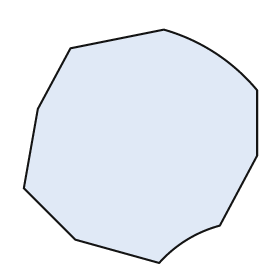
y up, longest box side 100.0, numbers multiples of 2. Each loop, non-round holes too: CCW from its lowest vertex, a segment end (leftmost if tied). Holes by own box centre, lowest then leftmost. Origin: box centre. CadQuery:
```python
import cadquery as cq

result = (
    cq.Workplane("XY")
    .moveTo(8.0, -50.0)
    .threePointArc((20.0, -40.0), (34.0, -34.0))
    .lineTo(50.0, -4.0)
    .lineTo(50.0, 24.0)
    .threePointArc((32.0, 40.0), (10.0, 50.0))
    .lineTo(-30.0, 42.0)
    .lineTo(-44.0, 16.0)
    .lineTo(-50.0, -18.0)
    .lineTo(-28.0, -40.0)
    .close()
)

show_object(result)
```